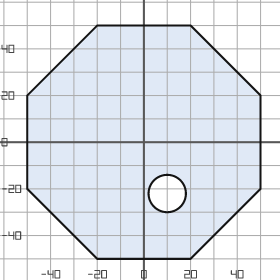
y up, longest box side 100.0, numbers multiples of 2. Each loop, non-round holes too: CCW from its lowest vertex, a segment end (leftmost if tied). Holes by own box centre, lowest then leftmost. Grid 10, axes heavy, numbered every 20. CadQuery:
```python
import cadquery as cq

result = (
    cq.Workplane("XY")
    .moveTo(-20.0, -50.0)
    .lineTo(20.0, -50.0)
    .lineTo(50.0, -20.0)
    .lineTo(50.0, 20.0)
    .lineTo(20.0, 50.0)
    .lineTo(-20.0, 50.0)
    .lineTo(-50.0, 20.0)
    .lineTo(-50.0, -20.0)
    .close()
    .moveTo(10.0, -22.0)
    .circle(8.0)
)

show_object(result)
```